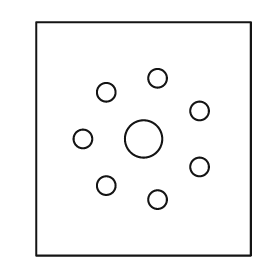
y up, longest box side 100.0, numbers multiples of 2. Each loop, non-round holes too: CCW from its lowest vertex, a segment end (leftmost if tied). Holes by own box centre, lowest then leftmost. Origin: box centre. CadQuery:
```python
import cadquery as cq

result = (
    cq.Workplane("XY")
    .moveTo(-46.0, -50.0)
    .lineTo(46.0, -50.0)
    .lineTo(46.0, 50.0)
    .lineTo(-46.0, 50.0)
    .close()
    .moveTo(6.0, -26.0)
    .circle(4.0)
    .moveTo(-16.0, -20.0)
    .circle(4.0)
    .moveTo(24.0, -12.0)
    .circle(4.0)
    .moveTo(-26.0, 0.0)
    .circle(4.0)
    .moveTo(0.0, 0.0)
    .circle(8.0)
    .moveTo(24.0, 12.0)
    .circle(4.0)
    .moveTo(-16.0, 20.0)
    .circle(4.0)
    .moveTo(6.0, 26.0)
    .circle(4.0)
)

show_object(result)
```